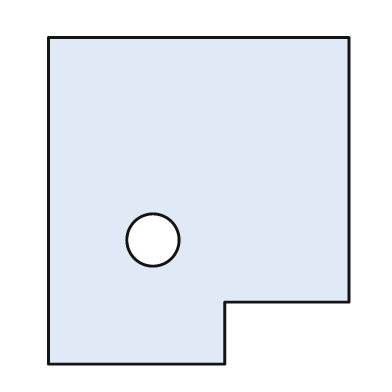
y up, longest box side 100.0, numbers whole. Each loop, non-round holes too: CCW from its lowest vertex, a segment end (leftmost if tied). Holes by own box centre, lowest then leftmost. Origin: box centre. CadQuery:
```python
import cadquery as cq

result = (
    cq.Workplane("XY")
    .moveTo(-46.0, -50.0)
    .lineTo(8.0, -50.0)
    .lineTo(8.0, -31.0)
    .lineTo(46.0, -31.0)
    .lineTo(46.0, 50.0)
    .lineTo(-46.0, 50.0)
    .close()
    .moveTo(-14.0, -12.0)
    .circle(8.0)
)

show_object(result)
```